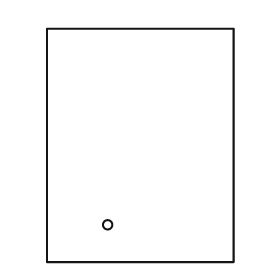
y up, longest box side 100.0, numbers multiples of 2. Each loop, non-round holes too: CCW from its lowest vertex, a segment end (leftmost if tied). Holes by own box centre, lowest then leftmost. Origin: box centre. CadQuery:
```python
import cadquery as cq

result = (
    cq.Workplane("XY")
    .moveTo(-40.0, -50.0)
    .lineTo(40.0, -50.0)
    .lineTo(40.0, 50.0)
    .lineTo(-40.0, 50.0)
    .close()
    .moveTo(-14.0, -34.0)
    .circle(2.0)
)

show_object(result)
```